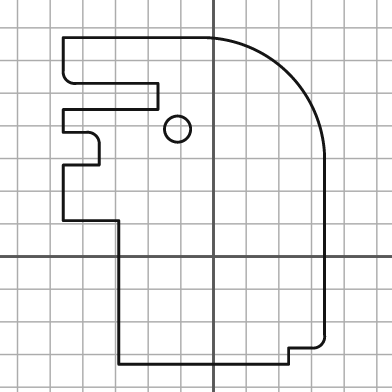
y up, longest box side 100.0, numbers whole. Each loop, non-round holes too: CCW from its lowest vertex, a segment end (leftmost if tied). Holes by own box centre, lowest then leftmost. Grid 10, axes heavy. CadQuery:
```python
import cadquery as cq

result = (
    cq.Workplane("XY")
    .moveTo(-29.0, -33.0)
    .lineTo(23.0, -33.0)
    .lineTo(23.0, -28.0)
    .lineTo(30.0, -28.0)
    .threePointArc((33.0, -27.0), (34.0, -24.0))
    .lineTo(34.0, 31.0)
    .threePointArc((23.0, 56.0), (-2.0, 67.0))
    .lineTo(-46.0, 67.0)
    .lineTo(-46.0, 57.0)
    .threePointArc((-45.0, 54.0), (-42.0, 53.0))
    .lineTo(-17.0, 53.0)
    .lineTo(-17.0, 45.0)
    .lineTo(-46.0, 45.0)
    .lineTo(-46.0, 38.0)
    .lineTo(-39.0, 38.0)
    .threePointArc((-36.0, 37.0), (-35.0, 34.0))
    .lineTo(-35.0, 28.0)
    .lineTo(-46.0, 28.0)
    .lineTo(-46.0, 11.0)
    .lineTo(-29.0, 11.0)
    .close()
    .moveTo(-11.0, 39.0)
    .circle(4.0)
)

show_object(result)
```